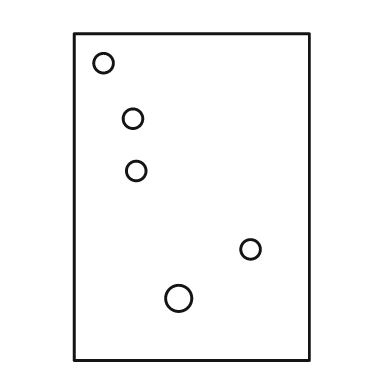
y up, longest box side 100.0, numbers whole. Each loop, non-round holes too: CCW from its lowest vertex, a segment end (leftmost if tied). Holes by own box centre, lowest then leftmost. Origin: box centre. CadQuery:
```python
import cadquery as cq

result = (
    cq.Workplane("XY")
    .moveTo(-36.0, -50.0)
    .lineTo(36.0, -50.0)
    .lineTo(36.0, 50.0)
    .lineTo(-36.0, 50.0)
    .close()
    .moveTo(-4.0, -31.0)
    .circle(4.0)
    .moveTo(18.0, -16.0)
    .circle(3.0)
    .moveTo(-17.0, 8.0)
    .circle(3.0)
    .moveTo(-18.0, 24.0)
    .circle(3.0)
    .moveTo(-27.0, 41.0)
    .circle(3.0)
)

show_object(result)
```